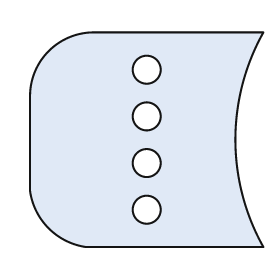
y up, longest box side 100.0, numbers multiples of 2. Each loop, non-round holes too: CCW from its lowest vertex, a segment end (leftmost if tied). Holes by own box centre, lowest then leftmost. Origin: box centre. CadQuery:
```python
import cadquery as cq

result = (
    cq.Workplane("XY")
    .moveTo(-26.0, -46.0)
    .lineTo(50.0, -46.0)
    .threePointArc((38.0, 0.0), (50.0, 46.0))
    .lineTo(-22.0, 46.0)
    .threePointArc((-42.0, 38.0), (-50.0, 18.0))
    .lineTo(-50.0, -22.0)
    .threePointArc((-42.0, -38.0), (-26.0, -46.0))
    .close()
    .moveTo(0.0, -30.0)
    .circle(6.0)
    .moveTo(0.0, -10.0)
    .circle(6.0)
    .moveTo(0.0, 10.0)
    .circle(6.0)
    .moveTo(0.0, 30.0)
    .circle(6.0)
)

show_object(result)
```